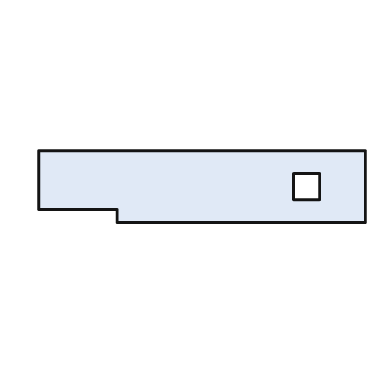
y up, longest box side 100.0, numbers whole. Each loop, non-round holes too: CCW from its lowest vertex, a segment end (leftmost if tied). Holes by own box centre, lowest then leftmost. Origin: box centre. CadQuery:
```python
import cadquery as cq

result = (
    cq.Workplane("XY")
    .moveTo(-26.0, -11.0)
    .lineTo(50.0, -11.0)
    .lineTo(50.0, 11.0)
    .lineTo(-50.0, 11.0)
    .lineTo(-50.0, -7.0)
    .lineTo(-26.0, -7.0)
    .close()
    .moveTo(28.0, -4.0)
    .lineTo(36.0, -4.0)
    .lineTo(36.0, 4.0)
    .lineTo(28.0, 4.0)
    .close()
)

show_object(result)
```